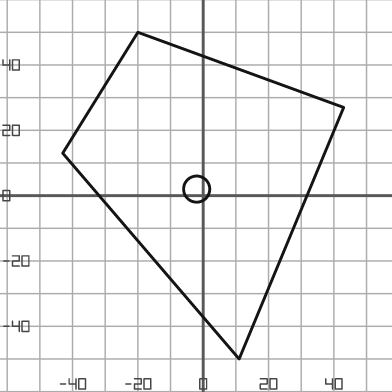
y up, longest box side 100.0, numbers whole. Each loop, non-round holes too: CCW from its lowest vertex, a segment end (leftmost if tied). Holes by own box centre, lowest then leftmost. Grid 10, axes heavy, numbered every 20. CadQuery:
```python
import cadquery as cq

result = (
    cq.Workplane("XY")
    .moveTo(11.0, -50.0)
    .lineTo(43.0, 27.0)
    .lineTo(-20.0, 50.0)
    .lineTo(-43.0, 13.0)
    .close()
    .moveTo(-2.0, 2.0)
    .circle(4.0)
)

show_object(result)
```